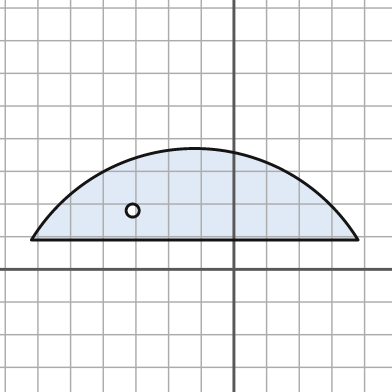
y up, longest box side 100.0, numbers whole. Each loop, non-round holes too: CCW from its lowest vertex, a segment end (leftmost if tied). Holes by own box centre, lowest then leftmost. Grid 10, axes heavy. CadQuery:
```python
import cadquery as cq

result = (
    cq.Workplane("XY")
    .moveTo(-62.0, 9.0)
    .lineTo(38.0, 9.0)
    .threePointArc((-12.0, 37.0), (-62.0, 9.0))
    .close()
    .moveTo(-31.0, 18.0)
    .circle(2.0)
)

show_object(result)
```